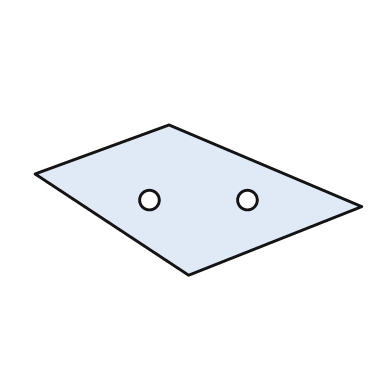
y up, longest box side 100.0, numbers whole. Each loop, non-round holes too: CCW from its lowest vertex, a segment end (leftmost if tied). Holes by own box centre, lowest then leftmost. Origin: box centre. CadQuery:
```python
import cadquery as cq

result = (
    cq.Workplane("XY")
    .moveTo(-3.0, -23.0)
    .lineTo(50.0, -2.0)
    .lineTo(-9.0, 23.0)
    .lineTo(-50.0, 8.0)
    .close()
    .moveTo(-15.0, 0.0)
    .circle(3.0)
    .moveTo(15.0, 0.0)
    .circle(3.0)
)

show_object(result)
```